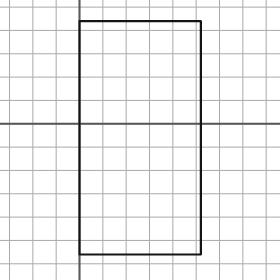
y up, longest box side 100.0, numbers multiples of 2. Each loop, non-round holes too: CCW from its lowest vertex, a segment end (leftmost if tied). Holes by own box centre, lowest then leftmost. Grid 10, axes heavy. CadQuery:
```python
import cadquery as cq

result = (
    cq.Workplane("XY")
    .moveTo(0.0, -56.0)
    .lineTo(52.0, -56.0)
    .lineTo(52.0, 44.0)
    .lineTo(0.0, 44.0)
    .close()
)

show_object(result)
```